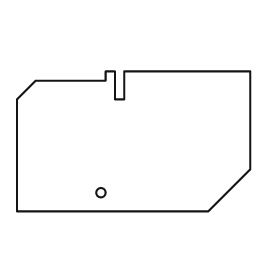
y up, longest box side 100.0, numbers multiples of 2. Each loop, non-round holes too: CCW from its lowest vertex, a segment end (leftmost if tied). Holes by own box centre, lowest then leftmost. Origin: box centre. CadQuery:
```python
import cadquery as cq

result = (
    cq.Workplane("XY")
    .moveTo(-50.0, -30.0)
    .lineTo(32.0, -30.0)
    .lineTo(50.0, -12.0)
    .lineTo(50.0, 30.0)
    .lineTo(-4.0, 30.0)
    .lineTo(-4.0, 18.0)
    .lineTo(-8.0, 18.0)
    .lineTo(-8.0, 30.0)
    .lineTo(-12.0, 30.0)
    .lineTo(-12.0, 26.0)
    .lineTo(-42.0, 26.0)
    .lineTo(-50.0, 18.0)
    .close()
    .moveTo(-14.0, -22.0)
    .circle(2.0)
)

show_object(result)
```